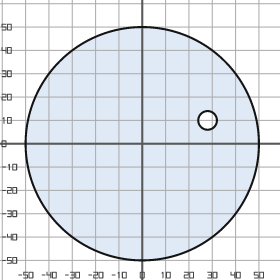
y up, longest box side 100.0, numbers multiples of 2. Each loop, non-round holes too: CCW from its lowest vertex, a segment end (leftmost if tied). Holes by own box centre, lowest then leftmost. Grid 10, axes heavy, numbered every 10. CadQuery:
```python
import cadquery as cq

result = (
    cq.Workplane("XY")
    .moveTo(0.0, 0.0)
    .circle(50.0)
    .moveTo(28.0, 10.0)
    .circle(4.0)
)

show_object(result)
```